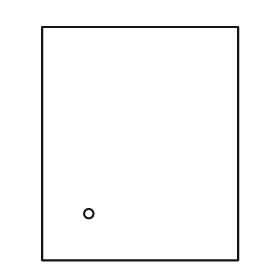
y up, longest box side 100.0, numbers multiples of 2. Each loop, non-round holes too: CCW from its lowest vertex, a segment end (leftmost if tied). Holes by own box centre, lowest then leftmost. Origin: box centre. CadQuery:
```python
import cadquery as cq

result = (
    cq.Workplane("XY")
    .moveTo(-42.0, -50.0)
    .lineTo(42.0, -50.0)
    .lineTo(42.0, 50.0)
    .lineTo(-42.0, 50.0)
    .close()
    .moveTo(-22.0, -30.0)
    .circle(2.0)
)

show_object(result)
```